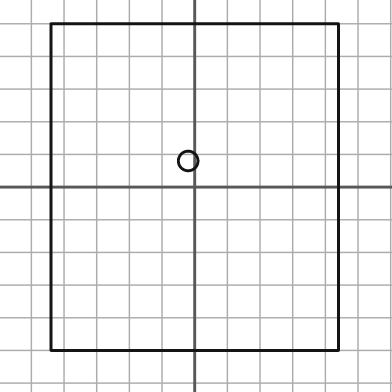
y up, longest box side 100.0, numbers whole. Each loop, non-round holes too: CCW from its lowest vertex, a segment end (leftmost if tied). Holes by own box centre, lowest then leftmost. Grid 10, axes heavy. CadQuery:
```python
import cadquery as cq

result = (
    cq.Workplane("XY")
    .moveTo(-44.0, -50.0)
    .lineTo(44.0, -50.0)
    .lineTo(44.0, 50.0)
    .lineTo(-44.0, 50.0)
    .close()
    .moveTo(-2.0, 8.0)
    .circle(3.0)
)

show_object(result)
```